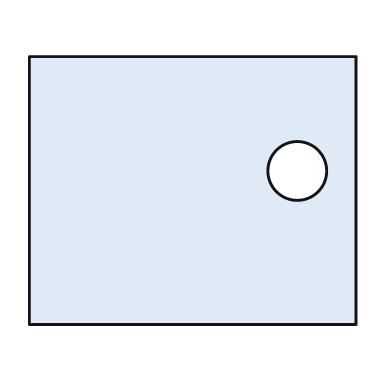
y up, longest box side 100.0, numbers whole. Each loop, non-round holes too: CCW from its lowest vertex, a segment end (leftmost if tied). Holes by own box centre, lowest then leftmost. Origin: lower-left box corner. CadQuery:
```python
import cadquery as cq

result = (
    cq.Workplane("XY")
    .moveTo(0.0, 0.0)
    .lineTo(100.0, 0.0)
    .lineTo(100.0, 82.0)
    .lineTo(0.0, 82.0)
    .close()
    .moveTo(82.0, 47.0)
    .circle(9.0)
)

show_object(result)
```